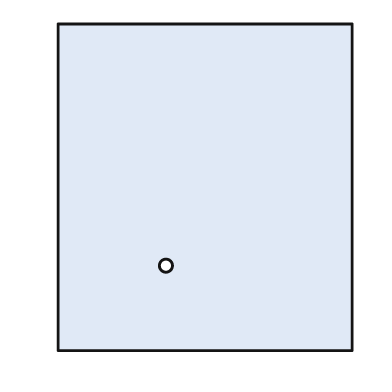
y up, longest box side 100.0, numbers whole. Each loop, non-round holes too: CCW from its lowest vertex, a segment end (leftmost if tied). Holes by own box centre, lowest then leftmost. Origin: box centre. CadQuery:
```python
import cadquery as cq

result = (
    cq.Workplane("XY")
    .moveTo(-45.0, -50.0)
    .lineTo(45.0, -50.0)
    .lineTo(45.0, 50.0)
    .lineTo(-45.0, 50.0)
    .close()
    .moveTo(-12.0, -24.0)
    .circle(2.0)
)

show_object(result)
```